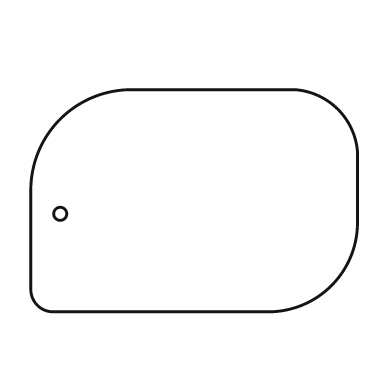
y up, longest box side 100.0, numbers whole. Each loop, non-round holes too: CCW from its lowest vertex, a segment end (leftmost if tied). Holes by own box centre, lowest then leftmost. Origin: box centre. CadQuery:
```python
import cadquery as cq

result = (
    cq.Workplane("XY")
    .moveTo(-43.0, -34.0)
    .lineTo(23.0, -34.0)
    .threePointArc((42.0, -26.0), (50.0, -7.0))
    .lineTo(50.0, 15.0)
    .threePointArc((44.0, 28.0), (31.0, 34.0))
    .lineTo(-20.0, 34.0)
    .threePointArc((-41.0, 25.0), (-50.0, 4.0))
    .lineTo(-50.0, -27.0)
    .threePointArc((-48.0, -32.0), (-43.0, -34.0))
    .close()
    .moveTo(-41.0, -4.0)
    .circle(2.0)
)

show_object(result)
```